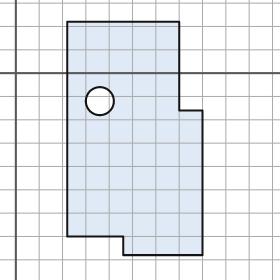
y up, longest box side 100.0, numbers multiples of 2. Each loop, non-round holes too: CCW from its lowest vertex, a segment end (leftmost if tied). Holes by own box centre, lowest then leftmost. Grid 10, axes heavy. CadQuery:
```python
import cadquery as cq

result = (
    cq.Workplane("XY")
    .moveTo(46.0, -78.0)
    .lineTo(80.0, -78.0)
    .lineTo(80.0, -16.0)
    .lineTo(70.0, -16.0)
    .lineTo(70.0, 22.0)
    .lineTo(22.0, 22.0)
    .lineTo(22.0, -70.0)
    .lineTo(46.0, -70.0)
    .close()
    .moveTo(36.0, -12.0)
    .circle(6.0)
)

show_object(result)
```